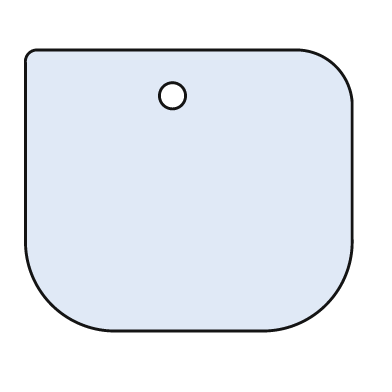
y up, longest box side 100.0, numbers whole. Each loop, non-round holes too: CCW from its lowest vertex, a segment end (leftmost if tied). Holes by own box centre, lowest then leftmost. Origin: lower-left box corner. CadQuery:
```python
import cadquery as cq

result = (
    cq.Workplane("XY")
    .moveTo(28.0, 0.0)
    .lineTo(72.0, 0.0)
    .threePointArc((92.0, 8.0), (100.0, 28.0))
    .lineTo(100.0, 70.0)
    .threePointArc((95.0, 81.0), (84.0, 86.0))
    .lineTo(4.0, 86.0)
    .threePointArc((1.0, 85.0), (0.0, 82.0))
    .lineTo(0.0, 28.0)
    .threePointArc((8.0, 8.0), (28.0, 0.0))
    .close()
    .moveTo(45.0, 72.0)
    .circle(4.0)
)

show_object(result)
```